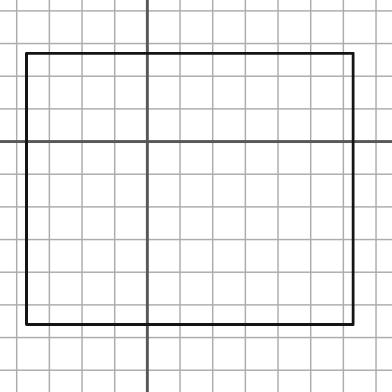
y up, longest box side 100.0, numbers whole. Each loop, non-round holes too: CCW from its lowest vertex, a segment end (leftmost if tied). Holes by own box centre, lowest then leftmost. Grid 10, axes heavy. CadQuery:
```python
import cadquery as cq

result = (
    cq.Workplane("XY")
    .moveTo(-37.0, -56.0)
    .lineTo(63.0, -56.0)
    .lineTo(63.0, 27.0)
    .lineTo(-37.0, 27.0)
    .close()
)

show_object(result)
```